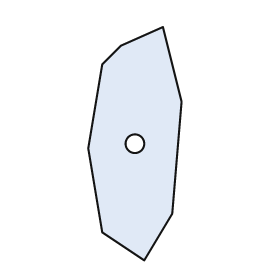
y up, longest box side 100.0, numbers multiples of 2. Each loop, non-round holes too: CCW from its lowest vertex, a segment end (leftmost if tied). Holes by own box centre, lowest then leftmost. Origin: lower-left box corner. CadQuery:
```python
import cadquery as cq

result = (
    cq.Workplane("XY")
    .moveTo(24.0, 0.0)
    .lineTo(36.0, 20.0)
    .lineTo(40.0, 68.0)
    .lineTo(32.0, 100.0)
    .lineTo(14.0, 92.0)
    .lineTo(6.0, 84.0)
    .lineTo(0.0, 48.0)
    .lineTo(6.0, 12.0)
    .close()
    .moveTo(20.0, 50.0)
    .circle(4.0)
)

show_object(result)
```